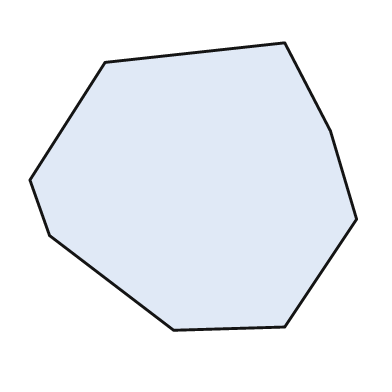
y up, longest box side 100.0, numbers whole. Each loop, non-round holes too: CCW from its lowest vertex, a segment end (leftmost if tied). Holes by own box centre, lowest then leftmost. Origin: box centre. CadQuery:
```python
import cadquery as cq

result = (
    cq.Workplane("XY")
    .moveTo(-6.0, -44.0)
    .lineTo(28.0, -43.0)
    .lineTo(50.0, -10.0)
    .lineTo(42.0, 17.0)
    .lineTo(28.0, 44.0)
    .lineTo(-27.0, 38.0)
    .lineTo(-50.0, 2.0)
    .lineTo(-44.0, -15.0)
    .close()
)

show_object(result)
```